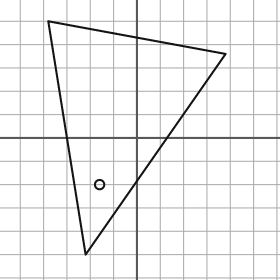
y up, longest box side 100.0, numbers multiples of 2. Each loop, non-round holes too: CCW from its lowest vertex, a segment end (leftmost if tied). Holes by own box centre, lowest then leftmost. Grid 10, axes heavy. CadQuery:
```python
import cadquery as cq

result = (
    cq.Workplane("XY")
    .moveTo(-22.0, -50.0)
    .lineTo(38.0, 36.0)
    .lineTo(-38.0, 50.0)
    .close()
    .moveTo(-16.0, -20.0)
    .circle(2.0)
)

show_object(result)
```